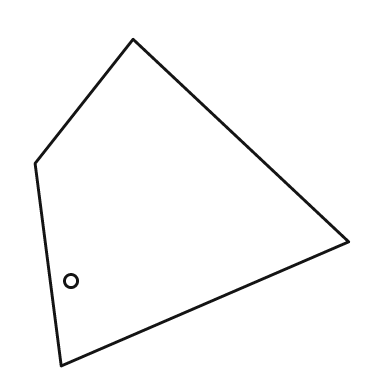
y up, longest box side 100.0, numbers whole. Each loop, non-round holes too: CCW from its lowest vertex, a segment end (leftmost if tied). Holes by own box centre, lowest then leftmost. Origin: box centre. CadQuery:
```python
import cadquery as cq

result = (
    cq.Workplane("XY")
    .moveTo(-40.0, -50.0)
    .lineTo(48.0, -12.0)
    .lineTo(-18.0, 50.0)
    .lineTo(-48.0, 12.0)
    .close()
    .moveTo(-37.0, -24.0)
    .circle(2.0)
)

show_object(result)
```